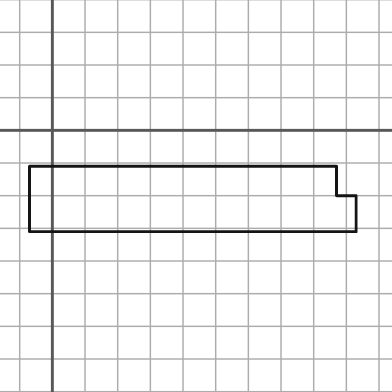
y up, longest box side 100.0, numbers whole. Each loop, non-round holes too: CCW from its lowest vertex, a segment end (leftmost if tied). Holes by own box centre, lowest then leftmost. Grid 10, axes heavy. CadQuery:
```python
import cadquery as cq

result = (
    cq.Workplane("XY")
    .moveTo(-7.0, -31.0)
    .lineTo(93.0, -31.0)
    .lineTo(93.0, -20.0)
    .lineTo(87.0, -20.0)
    .lineTo(87.0, -11.0)
    .lineTo(-7.0, -11.0)
    .close()
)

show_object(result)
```